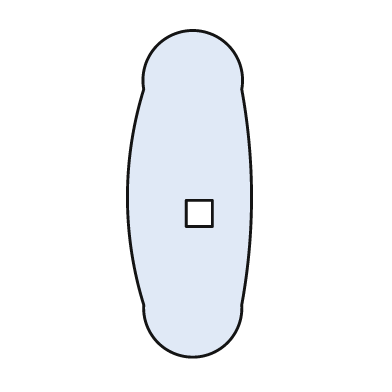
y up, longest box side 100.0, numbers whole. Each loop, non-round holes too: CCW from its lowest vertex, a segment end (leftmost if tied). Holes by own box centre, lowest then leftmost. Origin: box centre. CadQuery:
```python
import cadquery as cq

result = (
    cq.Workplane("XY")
    .moveTo(-14.0, -34.0)
    .threePointArc((1.0, -50.0), (16.0, -34.0))
    .threePointArc((19.0, -1.0), (16.0, 32.0))
    .threePointArc((1.0, 50.0), (-14.0, 32.0))
    .threePointArc((-19.0, -1.0), (-14.0, -34.0))
    .close()
    .moveTo(-1.0, -10.0)
    .lineTo(7.0, -10.0)
    .lineTo(7.0, -2.0)
    .lineTo(-1.0, -2.0)
    .close()
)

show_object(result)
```